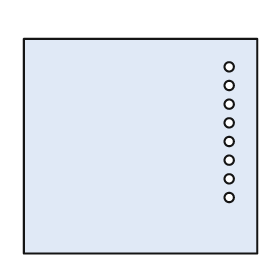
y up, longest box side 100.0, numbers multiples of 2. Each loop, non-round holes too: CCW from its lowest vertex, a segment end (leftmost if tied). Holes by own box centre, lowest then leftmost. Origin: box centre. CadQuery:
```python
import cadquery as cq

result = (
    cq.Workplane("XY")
    .moveTo(-50.0, -46.0)
    .lineTo(50.0, -46.0)
    .lineTo(50.0, 46.0)
    .lineTo(-50.0, 46.0)
    .close()
    .moveTo(38.0, -22.0)
    .circle(2.0)
    .moveTo(38.0, -14.0)
    .circle(2.0)
    .moveTo(38.0, -6.0)
    .circle(2.0)
    .moveTo(38.0, 2.0)
    .circle(2.0)
    .moveTo(38.0, 10.0)
    .circle(2.0)
    .moveTo(38.0, 18.0)
    .circle(2.0)
    .moveTo(38.0, 26.0)
    .circle(2.0)
    .moveTo(38.0, 34.0)
    .circle(2.0)
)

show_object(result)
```